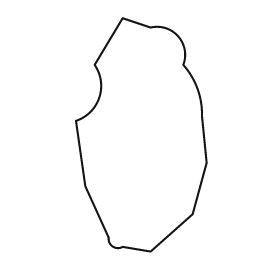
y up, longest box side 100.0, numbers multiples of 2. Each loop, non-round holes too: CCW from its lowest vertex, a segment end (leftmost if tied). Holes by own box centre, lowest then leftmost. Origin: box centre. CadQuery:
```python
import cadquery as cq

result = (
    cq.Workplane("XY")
    .moveTo(4.0, -50.0)
    .lineTo(22.0, -34.0)
    .lineTo(28.0, -12.0)
    .lineTo(26.0, 8.0)
    .threePointArc((24.0, 20.0), (18.0, 30.0))
    .threePointArc((16.0, 42.0), (4.0, 46.0))
    .lineTo(-8.0, 50.0)
    .lineTo(-20.0, 30.0)
    .threePointArc((-18.0, 16.0), (-28.0, 6.0))
    .lineTo(-24.0, -22.0)
    .lineTo(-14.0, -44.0)
    .threePointArc((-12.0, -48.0), (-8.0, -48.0))
    .close()
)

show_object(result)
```